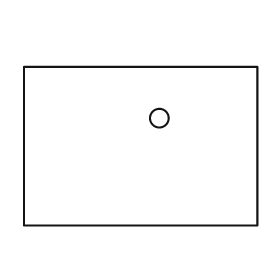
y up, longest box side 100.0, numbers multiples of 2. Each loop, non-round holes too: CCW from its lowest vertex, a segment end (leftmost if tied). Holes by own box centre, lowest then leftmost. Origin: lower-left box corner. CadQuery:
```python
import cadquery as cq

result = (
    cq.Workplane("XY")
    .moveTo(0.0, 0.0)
    .lineTo(100.0, 0.0)
    .lineTo(100.0, 68.0)
    .lineTo(0.0, 68.0)
    .close()
    .moveTo(58.0, 46.0)
    .circle(4.0)
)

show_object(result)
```